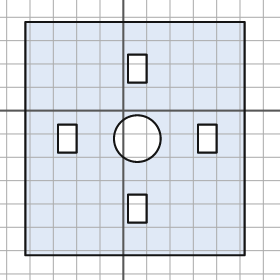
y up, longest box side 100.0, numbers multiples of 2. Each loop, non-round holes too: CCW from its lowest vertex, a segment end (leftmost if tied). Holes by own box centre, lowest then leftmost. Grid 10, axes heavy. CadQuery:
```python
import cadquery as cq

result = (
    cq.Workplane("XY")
    .moveTo(-42.0, -62.0)
    .lineTo(52.0, -62.0)
    .lineTo(52.0, 38.0)
    .lineTo(-42.0, 38.0)
    .close()
    .moveTo(2.0, -48.0)
    .lineTo(10.0, -48.0)
    .lineTo(10.0, -36.0)
    .lineTo(2.0, -36.0)
    .close()
    .moveTo(-28.0, -18.0)
    .lineTo(-20.0, -18.0)
    .lineTo(-20.0, -6.0)
    .lineTo(-28.0, -6.0)
    .close()
    .moveTo(6.0, -12.0)
    .circle(10.0)
    .moveTo(32.0, -18.0)
    .lineTo(40.0, -18.0)
    .lineTo(40.0, -6.0)
    .lineTo(32.0, -6.0)
    .close()
    .moveTo(2.0, 12.0)
    .lineTo(10.0, 12.0)
    .lineTo(10.0, 24.0)
    .lineTo(2.0, 24.0)
    .close()
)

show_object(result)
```